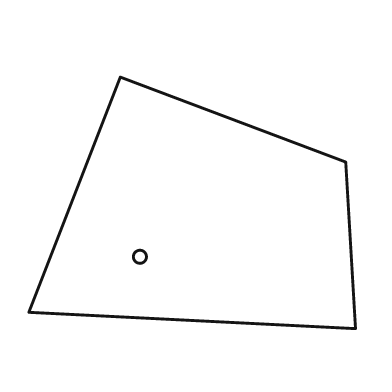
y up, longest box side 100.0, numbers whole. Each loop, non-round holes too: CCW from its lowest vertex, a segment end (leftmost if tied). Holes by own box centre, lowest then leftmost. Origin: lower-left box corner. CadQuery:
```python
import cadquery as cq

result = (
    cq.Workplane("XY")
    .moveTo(100.0, 0.0)
    .lineTo(97.0, 51.0)
    .lineTo(28.0, 77.0)
    .lineTo(0.0, 5.0)
    .close()
    .moveTo(34.0, 22.0)
    .circle(2.0)
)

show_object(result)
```